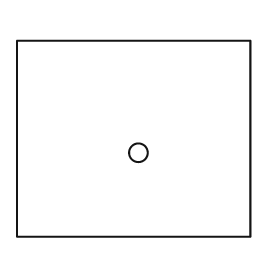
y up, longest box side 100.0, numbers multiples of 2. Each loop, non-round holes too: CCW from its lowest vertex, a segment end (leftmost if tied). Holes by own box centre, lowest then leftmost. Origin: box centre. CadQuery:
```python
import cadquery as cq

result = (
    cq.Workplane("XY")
    .moveTo(-50.0, -42.0)
    .lineTo(50.0, -42.0)
    .lineTo(50.0, 42.0)
    .lineTo(-50.0, 42.0)
    .close()
    .moveTo(2.0, -6.0)
    .circle(4.0)
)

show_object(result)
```